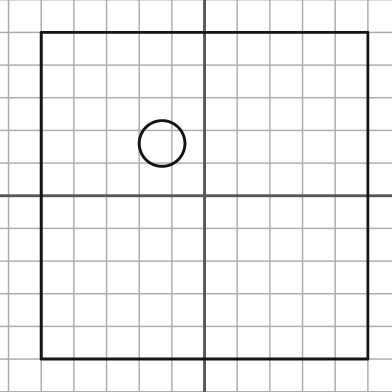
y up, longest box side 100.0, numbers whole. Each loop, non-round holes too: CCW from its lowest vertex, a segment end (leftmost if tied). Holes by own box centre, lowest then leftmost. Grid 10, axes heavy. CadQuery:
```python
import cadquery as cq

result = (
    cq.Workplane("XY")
    .moveTo(-50.0, -50.0)
    .lineTo(50.0, -50.0)
    .lineTo(50.0, 50.0)
    .lineTo(-50.0, 50.0)
    .close()
    .moveTo(-13.0, 16.0)
    .circle(7.0)
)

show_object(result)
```